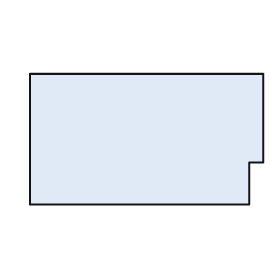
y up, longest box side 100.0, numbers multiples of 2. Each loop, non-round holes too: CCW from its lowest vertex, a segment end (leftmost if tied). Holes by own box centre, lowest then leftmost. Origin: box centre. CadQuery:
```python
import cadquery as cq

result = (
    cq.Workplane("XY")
    .moveTo(-50.0, -28.0)
    .lineTo(44.0, -28.0)
    .lineTo(44.0, -10.0)
    .lineTo(50.0, -10.0)
    .lineTo(50.0, 28.0)
    .lineTo(-50.0, 28.0)
    .close()
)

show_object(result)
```